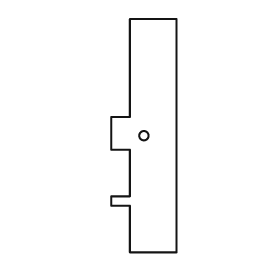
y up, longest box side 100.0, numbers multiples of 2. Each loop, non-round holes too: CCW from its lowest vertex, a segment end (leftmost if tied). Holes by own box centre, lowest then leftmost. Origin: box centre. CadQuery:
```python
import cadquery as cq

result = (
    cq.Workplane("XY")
    .moveTo(-6.0, -50.0)
    .lineTo(14.0, -50.0)
    .lineTo(14.0, 50.0)
    .lineTo(-6.0, 50.0)
    .lineTo(-6.0, 8.0)
    .lineTo(-14.0, 8.0)
    .lineTo(-14.0, -6.0)
    .lineTo(-6.0, -6.0)
    .lineTo(-6.0, -26.0)
    .lineTo(-14.0, -26.0)
    .lineTo(-14.0, -30.0)
    .lineTo(-6.0, -30.0)
    .close()
    .moveTo(0.0, 0.0)
    .circle(2.0)
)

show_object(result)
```